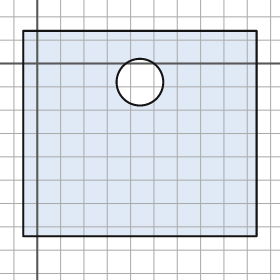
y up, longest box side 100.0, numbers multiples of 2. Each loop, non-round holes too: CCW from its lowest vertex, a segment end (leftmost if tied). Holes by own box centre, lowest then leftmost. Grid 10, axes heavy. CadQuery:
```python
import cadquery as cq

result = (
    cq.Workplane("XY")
    .moveTo(-6.0, -74.0)
    .lineTo(94.0, -74.0)
    .lineTo(94.0, 14.0)
    .lineTo(-6.0, 14.0)
    .close()
    .moveTo(44.0, -8.0)
    .circle(10.0)
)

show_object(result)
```